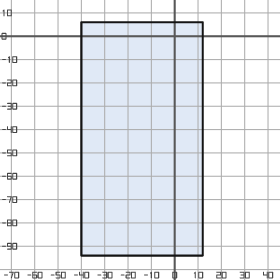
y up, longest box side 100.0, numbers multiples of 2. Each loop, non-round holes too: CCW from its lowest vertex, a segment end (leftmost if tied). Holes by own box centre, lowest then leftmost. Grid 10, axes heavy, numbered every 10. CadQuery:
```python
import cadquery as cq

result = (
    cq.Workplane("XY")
    .moveTo(-40.0, -94.0)
    .lineTo(12.0, -94.0)
    .lineTo(12.0, 6.0)
    .lineTo(-40.0, 6.0)
    .close()
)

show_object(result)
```